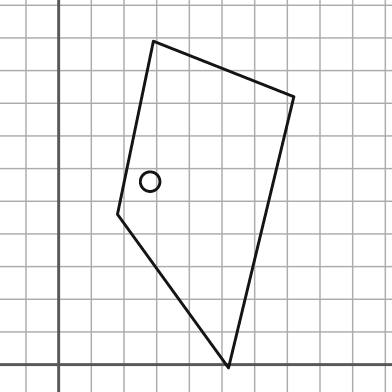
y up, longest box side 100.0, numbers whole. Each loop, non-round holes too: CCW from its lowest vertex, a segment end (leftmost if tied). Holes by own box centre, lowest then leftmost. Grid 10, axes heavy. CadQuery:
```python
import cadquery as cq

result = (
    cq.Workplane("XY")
    .moveTo(52.0, -1.0)
    .lineTo(72.0, 82.0)
    .lineTo(29.0, 99.0)
    .lineTo(18.0, 46.0)
    .close()
    .moveTo(28.0, 56.0)
    .circle(3.0)
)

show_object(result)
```